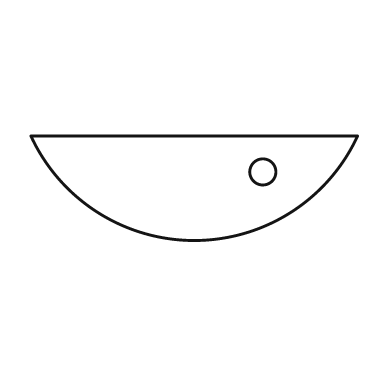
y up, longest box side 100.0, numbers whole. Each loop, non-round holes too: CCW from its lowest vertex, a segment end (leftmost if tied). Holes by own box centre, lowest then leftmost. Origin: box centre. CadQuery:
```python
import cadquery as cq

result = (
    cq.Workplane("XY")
    .moveTo(-50.0, 16.0)
    .threePointArc((0.0, -16.0), (50.0, 16.0))
    .close()
    .moveTo(21.0, 5.0)
    .circle(4.0)
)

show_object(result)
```